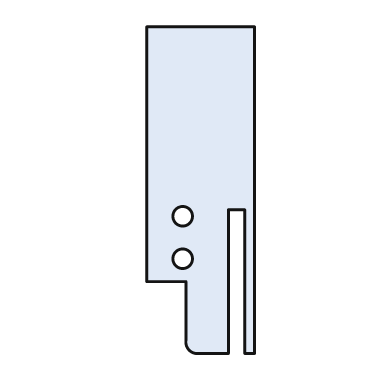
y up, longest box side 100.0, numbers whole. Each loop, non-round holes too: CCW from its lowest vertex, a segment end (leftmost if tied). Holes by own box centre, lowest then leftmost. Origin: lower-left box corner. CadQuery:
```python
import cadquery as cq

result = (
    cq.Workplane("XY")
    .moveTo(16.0, 0.0)
    .lineTo(25.0, 0.0)
    .lineTo(25.0, 44.0)
    .lineTo(30.0, 44.0)
    .lineTo(30.0, 0.0)
    .lineTo(33.0, 0.0)
    .lineTo(33.0, 100.0)
    .lineTo(0.0, 100.0)
    .lineTo(0.0, 22.0)
    .lineTo(12.0, 22.0)
    .lineTo(12.0, 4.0)
    .threePointArc((13.0, 1.0), (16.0, 0.0))
    .close()
    .moveTo(11.0, 29.0)
    .circle(3.0)
    .moveTo(11.0, 42.0)
    .circle(3.0)
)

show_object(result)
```